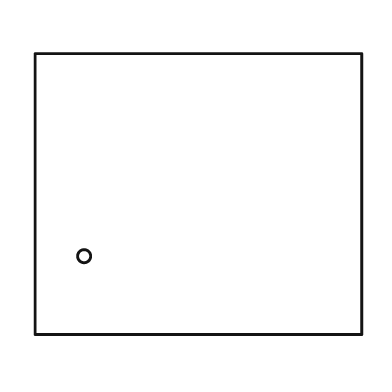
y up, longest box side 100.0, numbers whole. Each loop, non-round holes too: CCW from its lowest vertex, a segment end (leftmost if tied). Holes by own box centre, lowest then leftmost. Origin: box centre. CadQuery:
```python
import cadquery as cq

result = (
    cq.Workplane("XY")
    .moveTo(-50.0, -43.0)
    .lineTo(50.0, -43.0)
    .lineTo(50.0, 43.0)
    .lineTo(-50.0, 43.0)
    .close()
    .moveTo(-35.0, -19.0)
    .circle(2.0)
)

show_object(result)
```